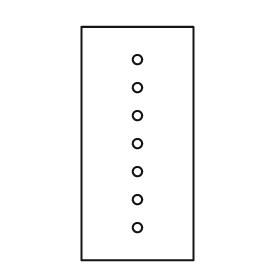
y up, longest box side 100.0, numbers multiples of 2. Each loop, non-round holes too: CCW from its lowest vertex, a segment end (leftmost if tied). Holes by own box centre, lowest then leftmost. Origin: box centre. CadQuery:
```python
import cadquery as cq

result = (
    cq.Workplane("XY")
    .moveTo(-24.0, -50.0)
    .lineTo(24.0, -50.0)
    .lineTo(24.0, 50.0)
    .lineTo(-24.0, 50.0)
    .close()
    .moveTo(0.0, -36.0)
    .circle(2.0)
    .moveTo(0.0, -24.0)
    .circle(2.0)
    .moveTo(0.0, -12.0)
    .circle(2.0)
    .moveTo(0.0, 0.0)
    .circle(2.0)
    .moveTo(0.0, 12.0)
    .circle(2.0)
    .moveTo(0.0, 24.0)
    .circle(2.0)
    .moveTo(0.0, 36.0)
    .circle(2.0)
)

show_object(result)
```